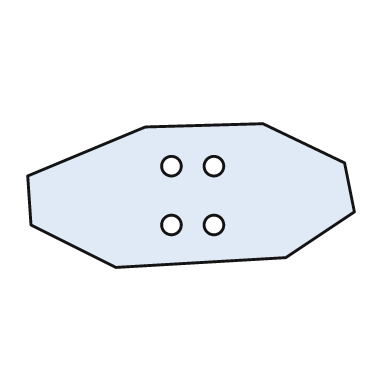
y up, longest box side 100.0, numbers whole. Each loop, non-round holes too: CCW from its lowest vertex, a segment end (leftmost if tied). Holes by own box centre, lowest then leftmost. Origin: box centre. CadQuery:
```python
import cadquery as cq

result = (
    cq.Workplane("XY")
    .moveTo(-23.0, -22.0)
    .lineTo(29.0, -19.0)
    .lineTo(50.0, -5.0)
    .lineTo(47.0, 10.0)
    .lineTo(22.0, 22.0)
    .lineTo(-14.0, 21.0)
    .lineTo(-50.0, 6.0)
    .lineTo(-49.0, -9.0)
    .close()
    .moveTo(-6.0, -9.0)
    .circle(3.0)
    .moveTo(7.0, -9.0)
    .circle(3.0)
    .moveTo(-6.0, 9.0)
    .circle(3.0)
    .moveTo(7.0, 9.0)
    .circle(3.0)
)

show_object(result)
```